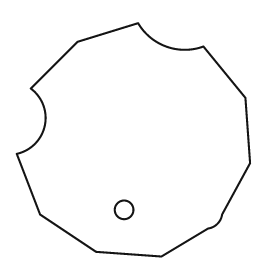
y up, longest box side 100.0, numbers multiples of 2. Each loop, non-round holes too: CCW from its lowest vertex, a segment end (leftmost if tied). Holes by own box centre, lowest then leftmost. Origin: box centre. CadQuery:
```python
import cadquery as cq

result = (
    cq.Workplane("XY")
    .moveTo(12.0, -50.0)
    .lineTo(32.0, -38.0)
    .threePointArc((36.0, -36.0), (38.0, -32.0))
    .lineTo(50.0, -10.0)
    .lineTo(48.0, 18.0)
    .lineTo(30.0, 40.0)
    .threePointArc((14.0, 40.0), (2.0, 50.0))
    .lineTo(-24.0, 42.0)
    .lineTo(-44.0, 22.0)
    .threePointArc((-38.0, 6.0), (-50.0, -6.0))
    .lineTo(-40.0, -32.0)
    .lineTo(-16.0, -48.0)
    .close()
    .moveTo(-4.0, -30.0)
    .circle(4.0)
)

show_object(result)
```